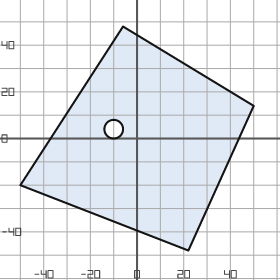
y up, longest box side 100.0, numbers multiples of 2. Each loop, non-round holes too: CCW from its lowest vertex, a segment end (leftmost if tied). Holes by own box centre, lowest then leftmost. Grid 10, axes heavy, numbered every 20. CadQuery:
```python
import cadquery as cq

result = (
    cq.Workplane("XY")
    .moveTo(22.0, -48.0)
    .lineTo(50.0, 14.0)
    .lineTo(-6.0, 48.0)
    .lineTo(-50.0, -20.0)
    .close()
    .moveTo(-10.0, 4.0)
    .circle(4.0)
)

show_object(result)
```